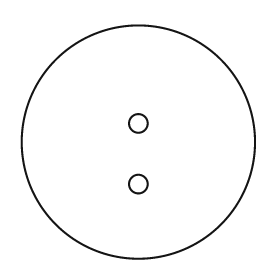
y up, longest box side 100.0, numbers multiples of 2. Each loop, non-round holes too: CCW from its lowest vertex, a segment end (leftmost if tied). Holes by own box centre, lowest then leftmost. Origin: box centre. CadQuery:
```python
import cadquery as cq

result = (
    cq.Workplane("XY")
    .moveTo(0.0, 0.0)
    .circle(50.0)
    .moveTo(0.0, -18.0)
    .circle(4.0)
    .moveTo(0.0, 8.0)
    .circle(4.0)
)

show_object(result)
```